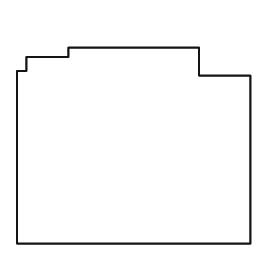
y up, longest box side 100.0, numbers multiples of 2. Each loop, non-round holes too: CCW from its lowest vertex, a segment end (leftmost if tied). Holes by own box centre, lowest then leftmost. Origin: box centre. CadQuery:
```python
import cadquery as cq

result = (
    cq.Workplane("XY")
    .moveTo(-50.0, -42.0)
    .lineTo(50.0, -42.0)
    .lineTo(50.0, 30.0)
    .lineTo(28.0, 30.0)
    .lineTo(28.0, 42.0)
    .lineTo(-28.0, 42.0)
    .lineTo(-28.0, 38.0)
    .lineTo(-46.0, 38.0)
    .lineTo(-46.0, 32.0)
    .lineTo(-50.0, 32.0)
    .close()
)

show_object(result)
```